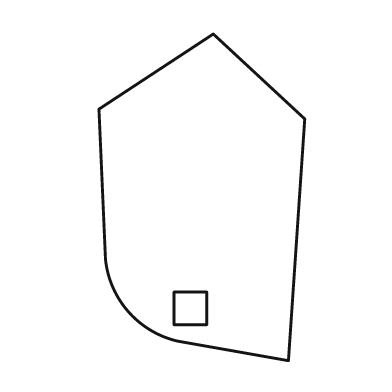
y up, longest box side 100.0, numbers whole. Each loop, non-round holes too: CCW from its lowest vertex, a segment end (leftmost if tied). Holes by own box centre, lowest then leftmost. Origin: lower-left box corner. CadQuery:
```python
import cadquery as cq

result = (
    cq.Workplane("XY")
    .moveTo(58.0, 0.0)
    .lineTo(63.0, 74.0)
    .lineTo(35.0, 100.0)
    .lineTo(0.0, 77.0)
    .lineTo(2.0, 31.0)
    .threePointArc((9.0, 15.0), (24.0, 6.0))
    .close()
    .moveTo(23.0, 11.0)
    .lineTo(33.0, 11.0)
    .lineTo(33.0, 21.0)
    .lineTo(23.0, 21.0)
    .close()
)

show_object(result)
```